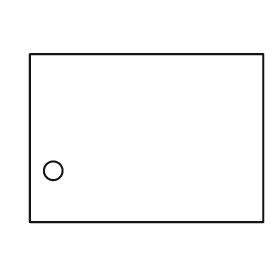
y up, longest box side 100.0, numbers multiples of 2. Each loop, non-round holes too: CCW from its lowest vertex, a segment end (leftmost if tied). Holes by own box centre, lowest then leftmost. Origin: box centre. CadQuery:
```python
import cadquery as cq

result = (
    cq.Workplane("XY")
    .moveTo(-50.0, -36.0)
    .lineTo(50.0, -36.0)
    .lineTo(50.0, 36.0)
    .lineTo(-50.0, 36.0)
    .close()
    .moveTo(-40.0, -14.0)
    .circle(4.0)
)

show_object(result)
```